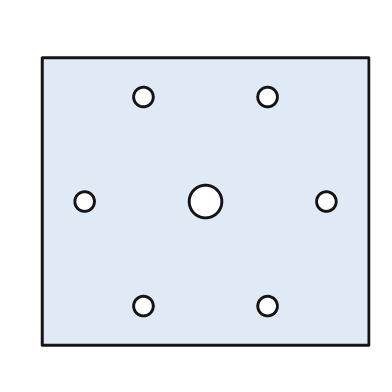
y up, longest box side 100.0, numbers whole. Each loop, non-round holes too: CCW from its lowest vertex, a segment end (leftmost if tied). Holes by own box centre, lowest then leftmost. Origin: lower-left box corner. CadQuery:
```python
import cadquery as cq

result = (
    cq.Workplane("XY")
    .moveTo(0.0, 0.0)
    .lineTo(100.0, 0.0)
    .lineTo(100.0, 88.0)
    .lineTo(0.0, 88.0)
    .close()
    .moveTo(31.0, 12.0)
    .circle(3.0)
    .moveTo(69.0, 12.0)
    .circle(3.0)
    .moveTo(13.0, 44.0)
    .circle(3.0)
    .moveTo(50.0, 44.0)
    .circle(5.0)
    .moveTo(87.0, 44.0)
    .circle(3.0)
    .moveTo(31.0, 76.0)
    .circle(3.0)
    .moveTo(69.0, 76.0)
    .circle(3.0)
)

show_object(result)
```